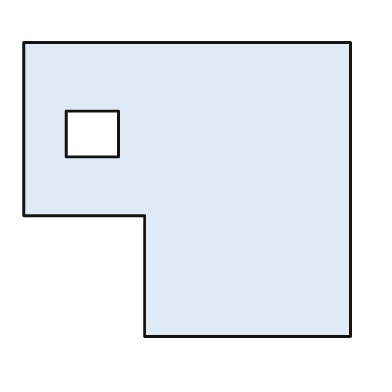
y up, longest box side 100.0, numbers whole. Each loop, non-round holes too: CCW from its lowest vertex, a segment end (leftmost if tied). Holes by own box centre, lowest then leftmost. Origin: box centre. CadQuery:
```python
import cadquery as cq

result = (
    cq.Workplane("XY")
    .moveTo(-13.0, -45.0)
    .lineTo(50.0, -45.0)
    .lineTo(50.0, 45.0)
    .lineTo(-50.0, 45.0)
    .lineTo(-50.0, -8.0)
    .lineTo(-13.0, -8.0)
    .close()
    .moveTo(-37.0, 10.0)
    .lineTo(-21.0, 10.0)
    .lineTo(-21.0, 24.0)
    .lineTo(-37.0, 24.0)
    .close()
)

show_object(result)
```